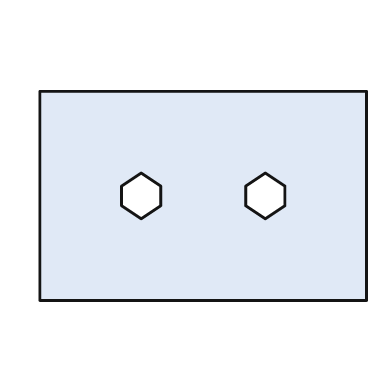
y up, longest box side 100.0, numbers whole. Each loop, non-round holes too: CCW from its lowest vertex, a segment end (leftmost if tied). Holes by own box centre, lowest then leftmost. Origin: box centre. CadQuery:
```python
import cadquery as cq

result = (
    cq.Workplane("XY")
    .moveTo(-50.0, -32.0)
    .lineTo(50.0, -32.0)
    .lineTo(50.0, 32.0)
    .lineTo(-50.0, 32.0)
    .close()
    .moveTo(-19.0, -7.0)
    .lineTo(-13.0, -3.0)
    .lineTo(-13.0, 3.0)
    .lineTo(-19.0, 7.0)
    .lineTo(-25.0, 3.0)
    .lineTo(-25.0, -3.0)
    .close()
    .moveTo(19.0, -7.0)
    .lineTo(25.0, -3.0)
    .lineTo(25.0, 3.0)
    .lineTo(19.0, 7.0)
    .lineTo(13.0, 3.0)
    .lineTo(13.0, -3.0)
    .close()
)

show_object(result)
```